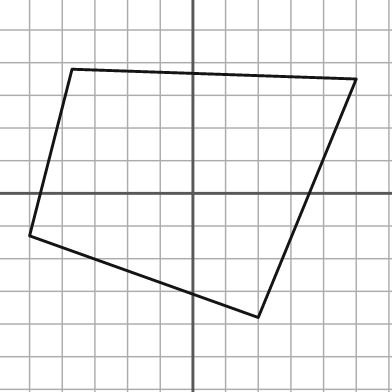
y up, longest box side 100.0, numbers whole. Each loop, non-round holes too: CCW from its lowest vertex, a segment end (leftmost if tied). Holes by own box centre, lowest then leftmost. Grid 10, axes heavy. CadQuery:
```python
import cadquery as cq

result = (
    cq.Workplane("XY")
    .moveTo(20.0, -38.0)
    .lineTo(50.0, 35.0)
    .lineTo(-37.0, 38.0)
    .lineTo(-50.0, -13.0)
    .close()
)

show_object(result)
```